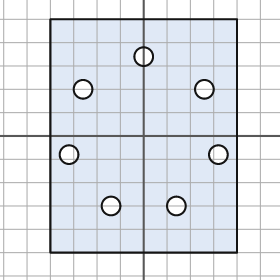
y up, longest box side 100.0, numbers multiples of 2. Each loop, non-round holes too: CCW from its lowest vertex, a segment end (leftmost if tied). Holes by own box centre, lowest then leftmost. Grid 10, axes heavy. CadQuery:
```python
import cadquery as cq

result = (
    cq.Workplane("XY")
    .moveTo(-40.0, -50.0)
    .lineTo(40.0, -50.0)
    .lineTo(40.0, 50.0)
    .lineTo(-40.0, 50.0)
    .close()
    .moveTo(-14.0, -30.0)
    .circle(4.0)
    .moveTo(14.0, -30.0)
    .circle(4.0)
    .moveTo(-32.0, -8.0)
    .circle(4.0)
    .moveTo(32.0, -8.0)
    .circle(4.0)
    .moveTo(-26.0, 20.0)
    .circle(4.0)
    .moveTo(26.0, 20.0)
    .circle(4.0)
    .moveTo(0.0, 34.0)
    .circle(4.0)
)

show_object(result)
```